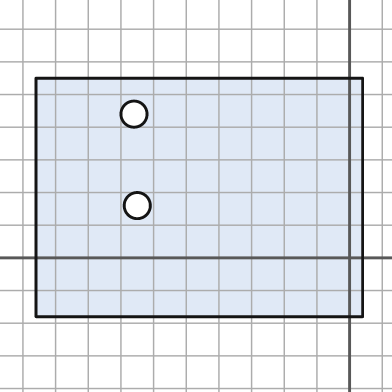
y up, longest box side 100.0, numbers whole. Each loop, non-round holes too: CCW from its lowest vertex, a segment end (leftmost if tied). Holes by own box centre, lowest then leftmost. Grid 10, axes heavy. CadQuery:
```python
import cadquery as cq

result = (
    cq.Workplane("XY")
    .moveTo(-96.0, -18.0)
    .lineTo(4.0, -18.0)
    .lineTo(4.0, 55.0)
    .lineTo(-96.0, 55.0)
    .close()
    .moveTo(-65.0, 16.0)
    .circle(4.0)
    .moveTo(-66.0, 44.0)
    .circle(4.0)
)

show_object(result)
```